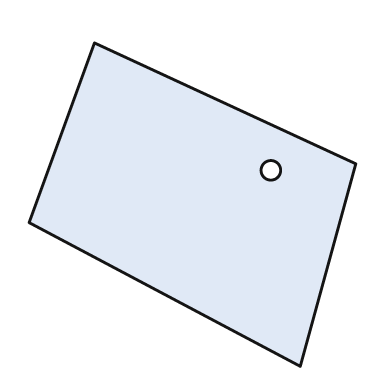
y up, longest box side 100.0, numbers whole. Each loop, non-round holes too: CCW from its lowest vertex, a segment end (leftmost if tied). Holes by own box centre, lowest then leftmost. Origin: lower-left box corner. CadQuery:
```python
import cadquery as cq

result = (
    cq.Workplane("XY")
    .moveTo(83.0, 0.0)
    .lineTo(100.0, 62.0)
    .lineTo(20.0, 99.0)
    .lineTo(0.0, 44.0)
    .close()
    .moveTo(74.0, 60.0)
    .circle(3.0)
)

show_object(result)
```